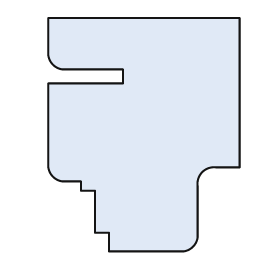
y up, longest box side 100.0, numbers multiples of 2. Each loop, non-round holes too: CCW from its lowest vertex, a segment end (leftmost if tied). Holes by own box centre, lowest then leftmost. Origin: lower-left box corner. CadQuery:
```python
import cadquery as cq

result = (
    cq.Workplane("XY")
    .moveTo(26.0, 0.0)
    .lineTo(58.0, 0.0)
    .threePointArc((62.0, 2.0), (64.0, 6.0))
    .lineTo(64.0, 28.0)
    .threePointArc((66.0, 34.0), (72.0, 36.0))
    .lineTo(82.0, 36.0)
    .lineTo(82.0, 100.0)
    .lineTo(0.0, 100.0)
    .lineTo(0.0, 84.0)
    .threePointArc((2.0, 80.0), (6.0, 78.0))
    .lineTo(32.0, 78.0)
    .lineTo(32.0, 72.0)
    .lineTo(0.0, 72.0)
    .lineTo(0.0, 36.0)
    .threePointArc((2.0, 32.0), (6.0, 30.0))
    .lineTo(14.0, 30.0)
    .lineTo(14.0, 26.0)
    .lineTo(20.0, 26.0)
    .lineTo(20.0, 8.0)
    .lineTo(26.0, 8.0)
    .close()
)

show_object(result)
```